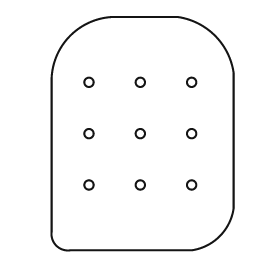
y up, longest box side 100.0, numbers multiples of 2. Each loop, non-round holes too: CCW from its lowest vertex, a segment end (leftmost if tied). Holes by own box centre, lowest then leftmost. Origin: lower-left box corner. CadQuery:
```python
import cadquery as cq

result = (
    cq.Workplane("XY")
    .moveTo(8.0, 0.0)
    .lineTo(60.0, 0.0)
    .threePointArc((72.0, 6.0), (78.0, 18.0))
    .lineTo(78.0, 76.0)
    .threePointArc((70.0, 92.0), (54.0, 100.0))
    .lineTo(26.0, 100.0)
    .threePointArc((8.0, 92.0), (0.0, 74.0))
    .lineTo(0.0, 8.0)
    .threePointArc((2.0, 2.0), (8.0, 0.0))
    .close()
    .moveTo(16.0, 28.0)
    .circle(2.0)
    .moveTo(38.0, 28.0)
    .circle(2.0)
    .moveTo(60.0, 28.0)
    .circle(2.0)
    .moveTo(16.0, 50.0)
    .circle(2.0)
    .moveTo(38.0, 50.0)
    .circle(2.0)
    .moveTo(60.0, 50.0)
    .circle(2.0)
    .moveTo(16.0, 72.0)
    .circle(2.0)
    .moveTo(38.0, 72.0)
    .circle(2.0)
    .moveTo(60.0, 72.0)
    .circle(2.0)
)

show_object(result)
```